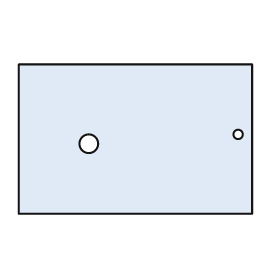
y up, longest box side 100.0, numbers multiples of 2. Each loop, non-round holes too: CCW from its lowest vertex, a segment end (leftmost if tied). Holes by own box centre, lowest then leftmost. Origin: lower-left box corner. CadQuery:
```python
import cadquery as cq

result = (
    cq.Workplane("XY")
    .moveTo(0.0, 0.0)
    .lineTo(100.0, 0.0)
    .lineTo(100.0, 64.0)
    .lineTo(0.0, 64.0)
    .close()
    .moveTo(30.0, 30.0)
    .circle(4.0)
    .moveTo(94.0, 34.0)
    .circle(2.0)
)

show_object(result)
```